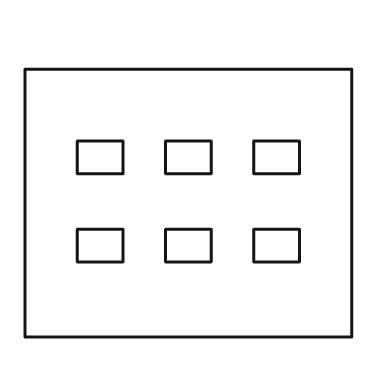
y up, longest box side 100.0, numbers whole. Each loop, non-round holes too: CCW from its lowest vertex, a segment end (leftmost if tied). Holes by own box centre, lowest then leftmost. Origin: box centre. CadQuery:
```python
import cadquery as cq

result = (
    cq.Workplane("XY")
    .moveTo(-50.0, -41.0)
    .lineTo(50.0, -41.0)
    .lineTo(50.0, 41.0)
    .lineTo(-50.0, 41.0)
    .close()
    .moveTo(-34.0, -18.0)
    .lineTo(-20.0, -18.0)
    .lineTo(-20.0, -8.0)
    .lineTo(-34.0, -8.0)
    .close()
    .moveTo(-7.0, -18.0)
    .lineTo(7.0, -18.0)
    .lineTo(7.0, -8.0)
    .lineTo(-7.0, -8.0)
    .close()
    .moveTo(20.0, -18.0)
    .lineTo(34.0, -18.0)
    .lineTo(34.0, -8.0)
    .lineTo(20.0, -8.0)
    .close()
    .moveTo(-34.0, 9.0)
    .lineTo(-20.0, 9.0)
    .lineTo(-20.0, 19.0)
    .lineTo(-34.0, 19.0)
    .close()
    .moveTo(-7.0, 9.0)
    .lineTo(7.0, 9.0)
    .lineTo(7.0, 19.0)
    .lineTo(-7.0, 19.0)
    .close()
    .moveTo(20.0, 9.0)
    .lineTo(34.0, 9.0)
    .lineTo(34.0, 19.0)
    .lineTo(20.0, 19.0)
    .close()
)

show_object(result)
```